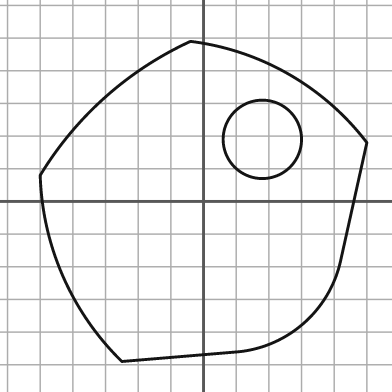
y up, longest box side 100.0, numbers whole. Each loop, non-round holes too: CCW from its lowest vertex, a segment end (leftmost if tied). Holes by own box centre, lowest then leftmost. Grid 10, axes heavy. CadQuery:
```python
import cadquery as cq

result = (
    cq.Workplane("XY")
    .moveTo(-25.0, -49.0)
    .lineTo(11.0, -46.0)
    .threePointArc((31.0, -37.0), (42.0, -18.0))
    .lineTo(50.0, 18.0)
    .threePointArc((26.0, 39.0), (-4.0, 49.0))
    .threePointArc((-30.0, 32.0), (-50.0, 8.0))
    .threePointArc((-43.0, -23.0), (-25.0, -49.0))
    .close()
    .moveTo(18.0, 19.0)
    .circle(12.0)
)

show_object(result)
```